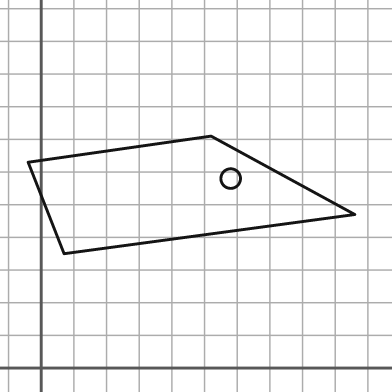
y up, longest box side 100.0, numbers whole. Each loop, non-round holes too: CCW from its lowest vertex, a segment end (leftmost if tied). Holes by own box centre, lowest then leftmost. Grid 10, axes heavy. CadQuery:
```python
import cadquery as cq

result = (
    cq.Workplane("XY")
    .moveTo(7.0, 35.0)
    .lineTo(96.0, 47.0)
    .lineTo(52.0, 71.0)
    .lineTo(-4.0, 63.0)
    .close()
    .moveTo(58.0, 58.0)
    .circle(3.0)
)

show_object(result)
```